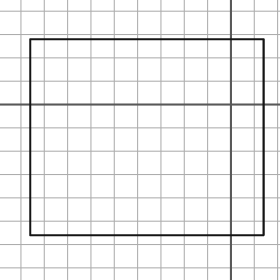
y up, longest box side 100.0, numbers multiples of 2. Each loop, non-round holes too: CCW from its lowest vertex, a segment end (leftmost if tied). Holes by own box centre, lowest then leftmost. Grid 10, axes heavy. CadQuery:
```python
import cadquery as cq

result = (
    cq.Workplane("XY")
    .moveTo(-86.0, -56.0)
    .lineTo(14.0, -56.0)
    .lineTo(14.0, 28.0)
    .lineTo(-86.0, 28.0)
    .close()
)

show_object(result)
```